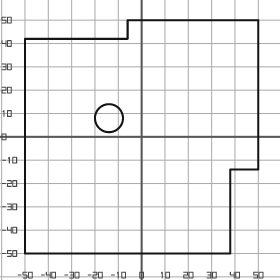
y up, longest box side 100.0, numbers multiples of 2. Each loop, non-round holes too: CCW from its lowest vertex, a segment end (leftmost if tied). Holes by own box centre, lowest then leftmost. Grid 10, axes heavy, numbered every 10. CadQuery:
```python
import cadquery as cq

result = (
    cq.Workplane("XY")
    .moveTo(-50.0, -50.0)
    .lineTo(38.0, -50.0)
    .lineTo(38.0, -14.0)
    .lineTo(50.0, -14.0)
    .lineTo(50.0, 50.0)
    .lineTo(-6.0, 50.0)
    .lineTo(-6.0, 42.0)
    .lineTo(-50.0, 42.0)
    .close()
    .moveTo(-14.0, 8.0)
    .circle(6.0)
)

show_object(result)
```